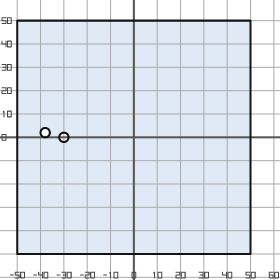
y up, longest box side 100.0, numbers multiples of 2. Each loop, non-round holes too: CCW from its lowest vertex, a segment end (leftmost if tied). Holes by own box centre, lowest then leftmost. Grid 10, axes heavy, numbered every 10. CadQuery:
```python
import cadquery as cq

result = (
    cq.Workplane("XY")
    .moveTo(-50.0, -50.0)
    .lineTo(50.0, -50.0)
    .lineTo(50.0, 50.0)
    .lineTo(-50.0, 50.0)
    .close()
    .moveTo(-30.0, 0.0)
    .circle(2.0)
    .moveTo(-38.0, 2.0)
    .circle(2.0)
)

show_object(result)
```